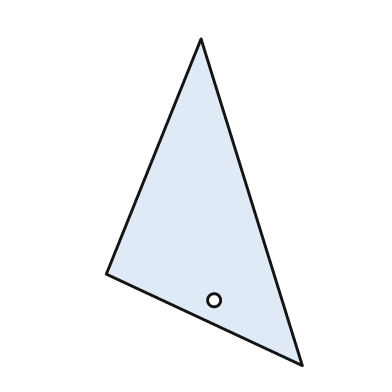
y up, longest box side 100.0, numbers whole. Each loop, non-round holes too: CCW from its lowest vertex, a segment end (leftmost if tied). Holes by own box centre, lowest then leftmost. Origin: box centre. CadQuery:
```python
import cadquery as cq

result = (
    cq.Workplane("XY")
    .moveTo(30.0, -50.0)
    .lineTo(-1.0, 50.0)
    .lineTo(-30.0, -22.0)
    .close()
    .moveTo(3.0, -30.0)
    .circle(2.0)
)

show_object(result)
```